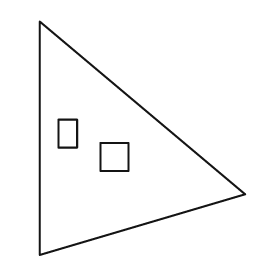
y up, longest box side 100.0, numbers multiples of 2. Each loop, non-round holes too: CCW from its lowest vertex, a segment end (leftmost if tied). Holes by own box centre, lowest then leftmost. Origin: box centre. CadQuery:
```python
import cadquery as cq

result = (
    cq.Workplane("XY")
    .moveTo(-44.0, -50.0)
    .lineTo(44.0, -24.0)
    .lineTo(-44.0, 50.0)
    .close()
    .moveTo(-18.0, -14.0)
    .lineTo(-6.0, -14.0)
    .lineTo(-6.0, -2.0)
    .lineTo(-18.0, -2.0)
    .close()
    .moveTo(-36.0, -4.0)
    .lineTo(-28.0, -4.0)
    .lineTo(-28.0, 8.0)
    .lineTo(-36.0, 8.0)
    .close()
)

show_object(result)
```